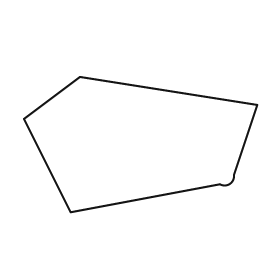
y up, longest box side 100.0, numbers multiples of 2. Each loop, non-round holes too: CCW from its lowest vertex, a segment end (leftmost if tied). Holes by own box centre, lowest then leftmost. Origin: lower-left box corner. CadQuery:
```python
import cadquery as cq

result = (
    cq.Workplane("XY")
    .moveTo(20.0, 0.0)
    .lineTo(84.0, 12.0)
    .threePointArc((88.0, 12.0), (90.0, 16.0))
    .lineTo(100.0, 46.0)
    .lineTo(24.0, 58.0)
    .lineTo(0.0, 40.0)
    .close()
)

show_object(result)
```